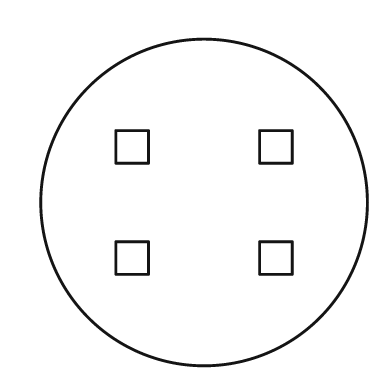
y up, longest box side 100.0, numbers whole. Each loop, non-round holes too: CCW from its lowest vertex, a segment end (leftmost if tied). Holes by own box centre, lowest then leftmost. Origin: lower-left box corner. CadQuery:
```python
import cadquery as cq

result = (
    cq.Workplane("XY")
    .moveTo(50.0, 50.0)
    .circle(50.0)
    .moveTo(23.0, 28.0)
    .lineTo(33.0, 28.0)
    .lineTo(33.0, 38.0)
    .lineTo(23.0, 38.0)
    .close()
    .moveTo(67.0, 28.0)
    .lineTo(77.0, 28.0)
    .lineTo(77.0, 38.0)
    .lineTo(67.0, 38.0)
    .close()
    .moveTo(23.0, 62.0)
    .lineTo(33.0, 62.0)
    .lineTo(33.0, 72.0)
    .lineTo(23.0, 72.0)
    .close()
    .moveTo(67.0, 62.0)
    .lineTo(77.0, 62.0)
    .lineTo(77.0, 72.0)
    .lineTo(67.0, 72.0)
    .close()
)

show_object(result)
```